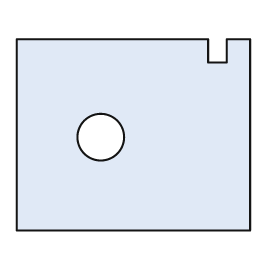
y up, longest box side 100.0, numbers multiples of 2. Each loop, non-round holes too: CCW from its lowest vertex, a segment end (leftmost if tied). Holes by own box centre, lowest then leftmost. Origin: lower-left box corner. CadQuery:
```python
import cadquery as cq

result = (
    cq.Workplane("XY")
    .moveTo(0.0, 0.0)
    .lineTo(100.0, 0.0)
    .lineTo(100.0, 82.0)
    .lineTo(90.0, 82.0)
    .lineTo(90.0, 72.0)
    .lineTo(82.0, 72.0)
    .lineTo(82.0, 82.0)
    .lineTo(0.0, 82.0)
    .close()
    .moveTo(36.0, 40.0)
    .circle(10.0)
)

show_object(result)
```